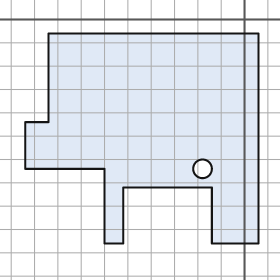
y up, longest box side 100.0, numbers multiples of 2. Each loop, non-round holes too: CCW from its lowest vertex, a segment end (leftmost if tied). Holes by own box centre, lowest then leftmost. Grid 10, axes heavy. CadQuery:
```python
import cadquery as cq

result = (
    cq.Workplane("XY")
    .moveTo(-60.0, -96.0)
    .lineTo(-52.0, -96.0)
    .lineTo(-52.0, -72.0)
    .lineTo(-14.0, -72.0)
    .lineTo(-14.0, -96.0)
    .lineTo(6.0, -96.0)
    .lineTo(6.0, -6.0)
    .lineTo(-84.0, -6.0)
    .lineTo(-84.0, -44.0)
    .lineTo(-94.0, -44.0)
    .lineTo(-94.0, -64.0)
    .lineTo(-60.0, -64.0)
    .close()
    .moveTo(-18.0, -64.0)
    .circle(4.0)
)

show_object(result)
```